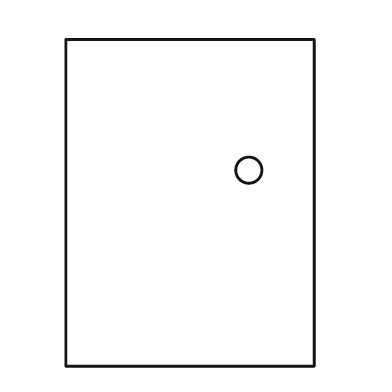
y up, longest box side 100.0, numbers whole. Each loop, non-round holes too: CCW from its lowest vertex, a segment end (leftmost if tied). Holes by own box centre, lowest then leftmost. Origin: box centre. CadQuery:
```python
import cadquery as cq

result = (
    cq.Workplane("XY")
    .moveTo(-38.0, -50.0)
    .lineTo(38.0, -50.0)
    .lineTo(38.0, 50.0)
    .lineTo(-38.0, 50.0)
    .close()
    .moveTo(18.0, 10.0)
    .circle(4.0)
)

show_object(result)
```